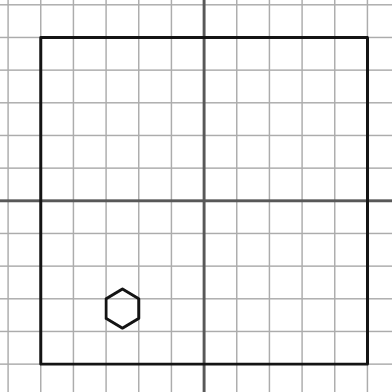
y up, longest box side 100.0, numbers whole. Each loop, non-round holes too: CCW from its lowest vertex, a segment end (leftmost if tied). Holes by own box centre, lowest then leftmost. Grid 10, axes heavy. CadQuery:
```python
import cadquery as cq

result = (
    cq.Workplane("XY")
    .moveTo(-50.0, -50.0)
    .lineTo(50.0, -50.0)
    .lineTo(50.0, 50.0)
    .lineTo(-50.0, 50.0)
    .close()
    .moveTo(-25.0, -39.0)
    .lineTo(-20.0, -36.0)
    .lineTo(-20.0, -30.0)
    .lineTo(-25.0, -27.0)
    .lineTo(-30.0, -30.0)
    .lineTo(-30.0, -36.0)
    .close()
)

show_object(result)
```